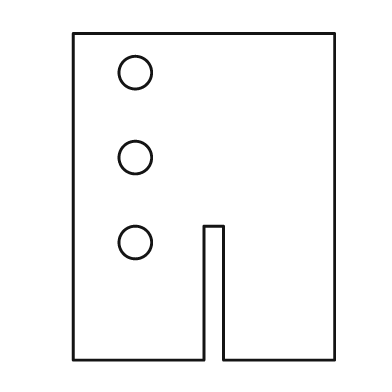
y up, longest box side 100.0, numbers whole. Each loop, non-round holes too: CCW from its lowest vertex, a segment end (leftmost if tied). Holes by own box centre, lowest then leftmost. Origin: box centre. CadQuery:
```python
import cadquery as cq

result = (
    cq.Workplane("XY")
    .moveTo(-40.0, -50.0)
    .lineTo(0.0, -50.0)
    .lineTo(0.0, -9.0)
    .lineTo(6.0, -9.0)
    .lineTo(6.0, -50.0)
    .lineTo(40.0, -50.0)
    .lineTo(40.0, 50.0)
    .lineTo(-40.0, 50.0)
    .close()
    .moveTo(-21.0, -14.0)
    .circle(5.0)
    .moveTo(-21.0, 12.0)
    .circle(5.0)
    .moveTo(-21.0, 38.0)
    .circle(5.0)
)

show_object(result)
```